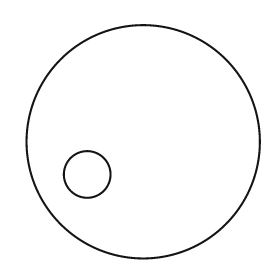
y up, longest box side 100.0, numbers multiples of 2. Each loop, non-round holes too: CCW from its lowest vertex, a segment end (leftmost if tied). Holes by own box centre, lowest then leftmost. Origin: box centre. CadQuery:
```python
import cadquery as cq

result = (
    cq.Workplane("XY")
    .moveTo(0.0, 0.0)
    .circle(50.0)
    .moveTo(-24.0, -14.0)
    .circle(10.0)
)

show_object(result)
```